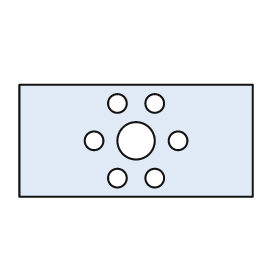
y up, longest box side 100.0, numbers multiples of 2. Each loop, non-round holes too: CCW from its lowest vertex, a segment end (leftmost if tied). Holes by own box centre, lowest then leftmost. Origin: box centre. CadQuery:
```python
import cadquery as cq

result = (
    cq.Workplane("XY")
    .moveTo(-50.0, -24.0)
    .lineTo(50.0, -24.0)
    .lineTo(50.0, 24.0)
    .lineTo(-50.0, 24.0)
    .close()
    .moveTo(-8.0, -16.0)
    .circle(4.0)
    .moveTo(8.0, -16.0)
    .circle(4.0)
    .moveTo(-18.0, 0.0)
    .circle(4.0)
    .moveTo(0.0, 0.0)
    .circle(8.0)
    .moveTo(18.0, 0.0)
    .circle(4.0)
    .moveTo(-8.0, 16.0)
    .circle(4.0)
    .moveTo(8.0, 16.0)
    .circle(4.0)
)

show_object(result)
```